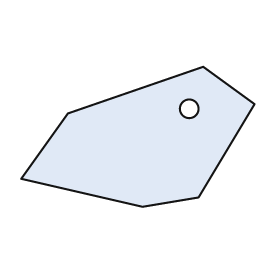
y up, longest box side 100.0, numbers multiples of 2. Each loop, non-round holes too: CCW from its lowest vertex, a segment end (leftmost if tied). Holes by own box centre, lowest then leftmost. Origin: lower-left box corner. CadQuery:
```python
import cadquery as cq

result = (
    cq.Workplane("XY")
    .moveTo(52.0, 0.0)
    .lineTo(76.0, 4.0)
    .lineTo(100.0, 44.0)
    .lineTo(78.0, 60.0)
    .lineTo(20.0, 40.0)
    .lineTo(0.0, 12.0)
    .close()
    .moveTo(72.0, 42.0)
    .circle(4.0)
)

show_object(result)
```